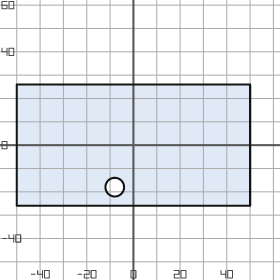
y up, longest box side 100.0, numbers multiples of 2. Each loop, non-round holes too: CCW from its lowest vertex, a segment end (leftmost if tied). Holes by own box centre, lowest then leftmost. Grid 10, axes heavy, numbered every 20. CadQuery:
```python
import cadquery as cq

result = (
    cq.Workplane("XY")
    .moveTo(-50.0, -26.0)
    .lineTo(50.0, -26.0)
    .lineTo(50.0, 26.0)
    .lineTo(-50.0, 26.0)
    .close()
    .moveTo(-8.0, -18.0)
    .circle(4.0)
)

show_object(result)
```